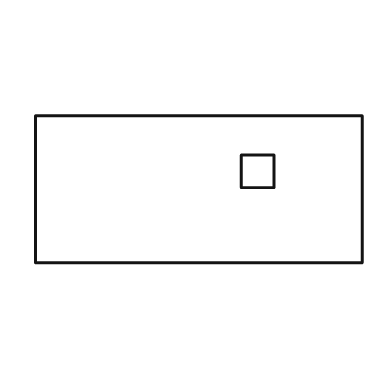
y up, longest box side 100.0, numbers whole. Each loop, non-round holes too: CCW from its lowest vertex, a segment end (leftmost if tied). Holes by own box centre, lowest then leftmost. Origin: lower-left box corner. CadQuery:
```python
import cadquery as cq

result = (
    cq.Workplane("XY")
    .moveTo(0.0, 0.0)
    .lineTo(100.0, 0.0)
    .lineTo(100.0, 45.0)
    .lineTo(0.0, 45.0)
    .close()
    .moveTo(63.0, 23.0)
    .lineTo(73.0, 23.0)
    .lineTo(73.0, 33.0)
    .lineTo(63.0, 33.0)
    .close()
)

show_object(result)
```